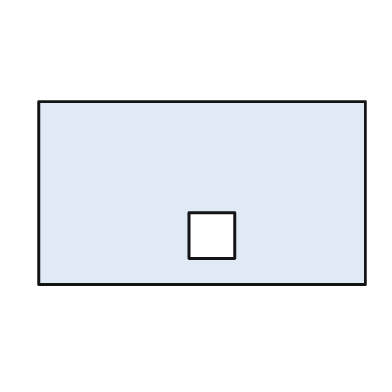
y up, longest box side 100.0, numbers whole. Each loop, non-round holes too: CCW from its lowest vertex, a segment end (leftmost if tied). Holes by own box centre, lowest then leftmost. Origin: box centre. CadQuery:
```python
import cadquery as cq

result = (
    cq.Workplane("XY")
    .moveTo(-50.0, -28.0)
    .lineTo(50.0, -28.0)
    .lineTo(50.0, 28.0)
    .lineTo(-50.0, 28.0)
    .close()
    .moveTo(-4.0, -20.0)
    .lineTo(10.0, -20.0)
    .lineTo(10.0, -6.0)
    .lineTo(-4.0, -6.0)
    .close()
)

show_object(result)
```